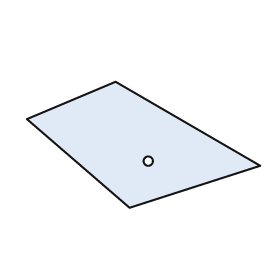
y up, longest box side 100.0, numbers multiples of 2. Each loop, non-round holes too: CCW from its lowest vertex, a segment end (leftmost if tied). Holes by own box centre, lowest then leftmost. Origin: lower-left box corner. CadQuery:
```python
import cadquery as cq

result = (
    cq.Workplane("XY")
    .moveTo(44.0, 0.0)
    .lineTo(100.0, 18.0)
    .lineTo(38.0, 54.0)
    .lineTo(0.0, 38.0)
    .close()
    .moveTo(52.0, 20.0)
    .circle(2.0)
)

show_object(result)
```